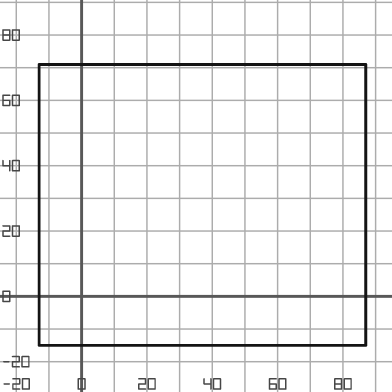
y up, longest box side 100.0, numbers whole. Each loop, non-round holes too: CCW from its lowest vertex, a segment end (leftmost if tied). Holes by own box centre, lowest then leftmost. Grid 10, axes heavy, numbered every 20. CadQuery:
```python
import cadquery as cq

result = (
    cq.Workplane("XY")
    .moveTo(-13.0, -15.0)
    .lineTo(87.0, -15.0)
    .lineTo(87.0, 71.0)
    .lineTo(-13.0, 71.0)
    .close()
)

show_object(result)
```